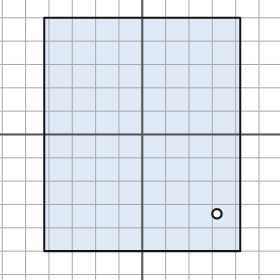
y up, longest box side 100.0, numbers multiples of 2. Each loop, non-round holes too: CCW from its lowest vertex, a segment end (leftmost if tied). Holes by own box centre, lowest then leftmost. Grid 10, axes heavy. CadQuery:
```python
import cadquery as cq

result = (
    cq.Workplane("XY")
    .moveTo(-42.0, -50.0)
    .lineTo(42.0, -50.0)
    .lineTo(42.0, 50.0)
    .lineTo(-42.0, 50.0)
    .close()
    .moveTo(32.0, -34.0)
    .circle(2.0)
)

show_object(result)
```